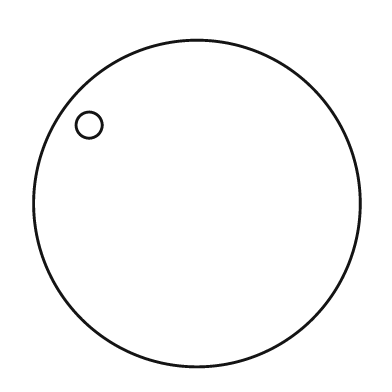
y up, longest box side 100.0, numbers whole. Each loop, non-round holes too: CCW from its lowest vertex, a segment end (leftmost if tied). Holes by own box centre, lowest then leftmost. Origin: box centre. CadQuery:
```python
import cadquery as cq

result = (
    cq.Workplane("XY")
    .moveTo(0.0, 0.0)
    .circle(50.0)
    .moveTo(-33.0, 24.0)
    .circle(4.0)
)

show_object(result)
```